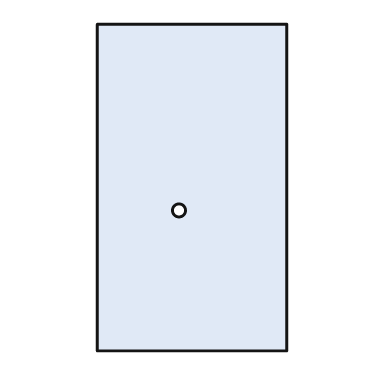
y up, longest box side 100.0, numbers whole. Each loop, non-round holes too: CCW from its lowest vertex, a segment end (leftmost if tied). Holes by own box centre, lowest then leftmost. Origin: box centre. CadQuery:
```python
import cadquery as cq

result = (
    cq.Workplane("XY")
    .moveTo(-29.0, -50.0)
    .lineTo(29.0, -50.0)
    .lineTo(29.0, 50.0)
    .lineTo(-29.0, 50.0)
    .close()
    .moveTo(-4.0, -7.0)
    .circle(2.0)
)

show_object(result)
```